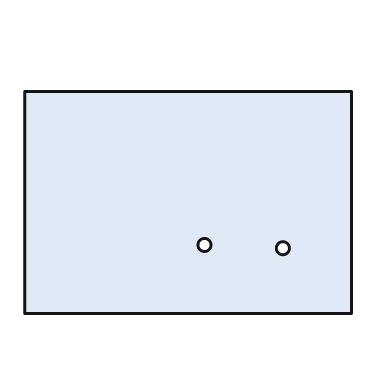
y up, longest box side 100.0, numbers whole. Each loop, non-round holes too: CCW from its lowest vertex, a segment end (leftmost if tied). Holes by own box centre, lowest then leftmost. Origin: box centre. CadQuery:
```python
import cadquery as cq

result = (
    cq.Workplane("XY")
    .moveTo(-50.0, -34.0)
    .lineTo(50.0, -34.0)
    .lineTo(50.0, 34.0)
    .lineTo(-50.0, 34.0)
    .close()
    .moveTo(29.0, -14.0)
    .circle(2.0)
    .moveTo(5.0, -13.0)
    .circle(2.0)
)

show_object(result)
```